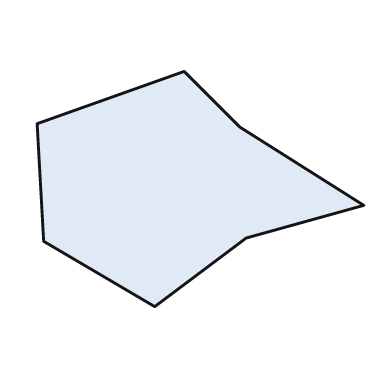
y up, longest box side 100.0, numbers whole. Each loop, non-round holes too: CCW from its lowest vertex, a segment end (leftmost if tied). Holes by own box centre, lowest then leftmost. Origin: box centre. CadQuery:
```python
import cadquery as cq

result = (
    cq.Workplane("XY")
    .moveTo(-14.0, -36.0)
    .lineTo(14.0, -15.0)
    .lineTo(50.0, -5.0)
    .lineTo(12.0, 19.0)
    .lineTo(-5.0, 36.0)
    .lineTo(-50.0, 20.0)
    .lineTo(-48.0, -16.0)
    .close()
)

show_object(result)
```